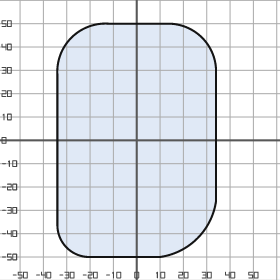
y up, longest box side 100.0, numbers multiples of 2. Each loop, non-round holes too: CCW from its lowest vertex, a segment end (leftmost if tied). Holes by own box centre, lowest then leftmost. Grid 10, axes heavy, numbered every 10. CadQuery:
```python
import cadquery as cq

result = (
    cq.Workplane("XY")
    .moveTo(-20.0, -50.0)
    .lineTo(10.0, -50.0)
    .threePointArc((26.0, -42.0), (34.0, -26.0))
    .lineTo(34.0, 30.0)
    .threePointArc((28.0, 44.0), (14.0, 50.0))
    .lineTo(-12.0, 50.0)
    .threePointArc((-28.0, 44.0), (-34.0, 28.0))
    .lineTo(-34.0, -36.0)
    .threePointArc((-30.0, -46.0), (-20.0, -50.0))
    .close()
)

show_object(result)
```